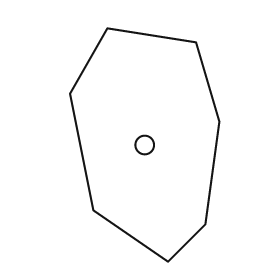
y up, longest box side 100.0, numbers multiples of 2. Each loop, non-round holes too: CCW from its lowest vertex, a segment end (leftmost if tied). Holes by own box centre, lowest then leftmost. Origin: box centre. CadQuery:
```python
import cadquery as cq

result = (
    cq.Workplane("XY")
    .moveTo(10.0, -50.0)
    .lineTo(26.0, -34.0)
    .lineTo(32.0, 10.0)
    .lineTo(22.0, 44.0)
    .lineTo(-16.0, 50.0)
    .lineTo(-32.0, 22.0)
    .lineTo(-22.0, -28.0)
    .close()
    .moveTo(0.0, 0.0)
    .circle(4.0)
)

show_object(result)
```